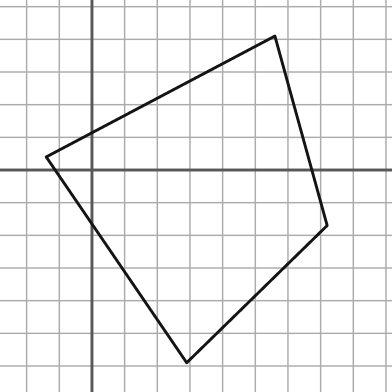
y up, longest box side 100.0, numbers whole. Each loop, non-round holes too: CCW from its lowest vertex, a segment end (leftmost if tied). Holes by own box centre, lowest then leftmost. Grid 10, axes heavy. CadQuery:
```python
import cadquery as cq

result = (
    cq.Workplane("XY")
    .moveTo(29.0, -59.0)
    .lineTo(72.0, -17.0)
    .lineTo(56.0, 41.0)
    .lineTo(-14.0, 4.0)
    .close()
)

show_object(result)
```